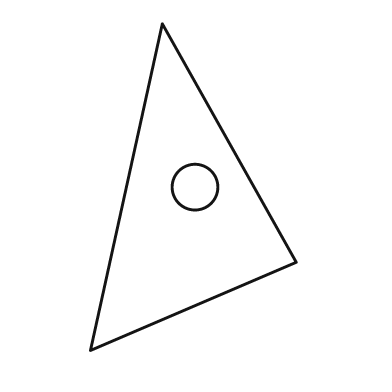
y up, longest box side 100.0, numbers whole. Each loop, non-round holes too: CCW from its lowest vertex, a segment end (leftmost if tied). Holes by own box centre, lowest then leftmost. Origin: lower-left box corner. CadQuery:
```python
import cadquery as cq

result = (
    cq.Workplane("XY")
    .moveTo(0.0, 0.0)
    .lineTo(63.0, 27.0)
    .lineTo(22.0, 100.0)
    .close()
    .moveTo(32.0, 50.0)
    .circle(7.0)
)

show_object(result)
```